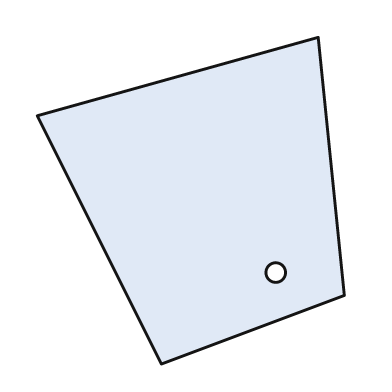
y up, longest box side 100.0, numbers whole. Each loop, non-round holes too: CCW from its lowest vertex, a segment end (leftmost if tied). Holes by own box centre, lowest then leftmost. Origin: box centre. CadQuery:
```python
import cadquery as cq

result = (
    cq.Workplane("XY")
    .moveTo(-9.0, -50.0)
    .lineTo(47.0, -29.0)
    .lineTo(39.0, 50.0)
    .lineTo(-47.0, 26.0)
    .close()
    .moveTo(26.0, -22.0)
    .circle(3.0)
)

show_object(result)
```